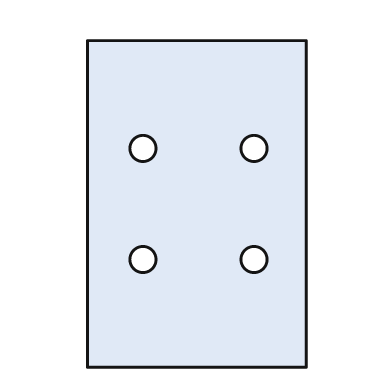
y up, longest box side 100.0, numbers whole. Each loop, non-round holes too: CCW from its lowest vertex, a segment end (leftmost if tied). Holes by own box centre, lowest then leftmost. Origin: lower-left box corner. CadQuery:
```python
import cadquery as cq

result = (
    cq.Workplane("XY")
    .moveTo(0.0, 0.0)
    .lineTo(67.0, 0.0)
    .lineTo(67.0, 100.0)
    .lineTo(0.0, 100.0)
    .close()
    .moveTo(17.0, 33.0)
    .circle(4.0)
    .moveTo(51.0, 33.0)
    .circle(4.0)
    .moveTo(17.0, 67.0)
    .circle(4.0)
    .moveTo(51.0, 67.0)
    .circle(4.0)
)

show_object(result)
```